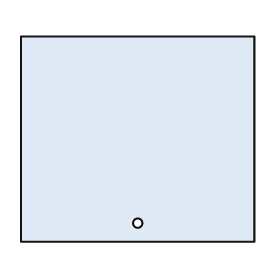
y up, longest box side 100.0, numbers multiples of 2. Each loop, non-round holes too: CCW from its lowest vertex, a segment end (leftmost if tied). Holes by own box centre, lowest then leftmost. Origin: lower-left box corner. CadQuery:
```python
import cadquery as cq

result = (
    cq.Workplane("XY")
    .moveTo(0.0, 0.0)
    .lineTo(100.0, 0.0)
    .lineTo(100.0, 88.0)
    .lineTo(0.0, 88.0)
    .close()
    .moveTo(50.0, 8.0)
    .circle(2.0)
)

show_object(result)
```